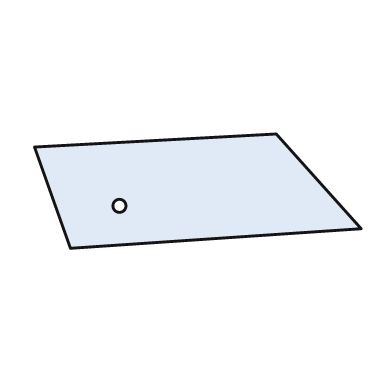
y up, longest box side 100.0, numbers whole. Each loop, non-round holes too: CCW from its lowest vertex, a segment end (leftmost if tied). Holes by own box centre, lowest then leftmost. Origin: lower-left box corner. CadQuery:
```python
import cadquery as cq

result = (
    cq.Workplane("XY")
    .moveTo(11.0, 0.0)
    .lineTo(100.0, 6.0)
    .lineTo(74.0, 35.0)
    .lineTo(0.0, 31.0)
    .close()
    .moveTo(26.0, 13.0)
    .circle(2.0)
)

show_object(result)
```